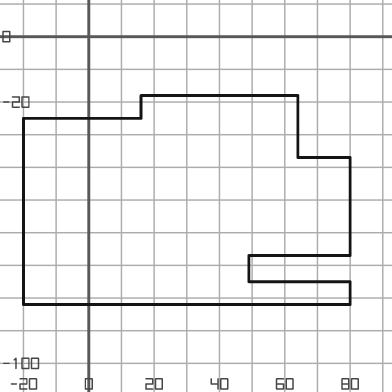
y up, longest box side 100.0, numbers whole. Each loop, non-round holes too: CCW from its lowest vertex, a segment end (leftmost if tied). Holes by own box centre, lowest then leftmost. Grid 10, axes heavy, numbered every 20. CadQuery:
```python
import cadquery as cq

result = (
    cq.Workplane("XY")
    .moveTo(-20.0, -82.0)
    .lineTo(80.0, -82.0)
    .lineTo(80.0, -75.0)
    .lineTo(49.0, -75.0)
    .lineTo(49.0, -67.0)
    .lineTo(80.0, -67.0)
    .lineTo(80.0, -37.0)
    .lineTo(64.0, -37.0)
    .lineTo(64.0, -18.0)
    .lineTo(16.0, -18.0)
    .lineTo(16.0, -25.0)
    .lineTo(-20.0, -25.0)
    .close()
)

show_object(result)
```